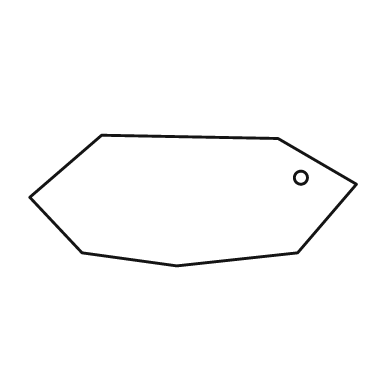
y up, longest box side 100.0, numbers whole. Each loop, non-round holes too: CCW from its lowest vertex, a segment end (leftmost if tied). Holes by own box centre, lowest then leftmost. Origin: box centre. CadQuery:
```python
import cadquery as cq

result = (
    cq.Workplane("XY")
    .moveTo(-5.0, -20.0)
    .lineTo(32.0, -16.0)
    .lineTo(50.0, 5.0)
    .lineTo(26.0, 19.0)
    .lineTo(-28.0, 20.0)
    .lineTo(-50.0, 1.0)
    .lineTo(-34.0, -16.0)
    .close()
    .moveTo(33.0, 7.0)
    .circle(2.0)
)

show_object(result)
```